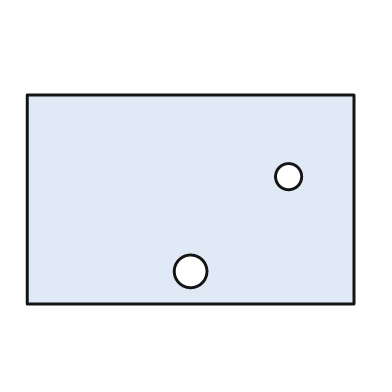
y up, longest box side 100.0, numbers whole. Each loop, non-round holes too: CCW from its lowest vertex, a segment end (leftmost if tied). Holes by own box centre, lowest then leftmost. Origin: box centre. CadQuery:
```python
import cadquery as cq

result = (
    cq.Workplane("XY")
    .moveTo(-50.0, -32.0)
    .lineTo(50.0, -32.0)
    .lineTo(50.0, 32.0)
    .lineTo(-50.0, 32.0)
    .close()
    .moveTo(0.0, -22.0)
    .circle(5.0)
    .moveTo(30.0, 7.0)
    .circle(4.0)
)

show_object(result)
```